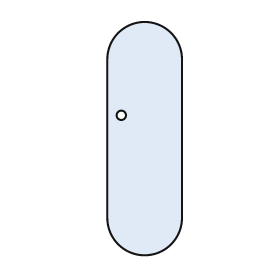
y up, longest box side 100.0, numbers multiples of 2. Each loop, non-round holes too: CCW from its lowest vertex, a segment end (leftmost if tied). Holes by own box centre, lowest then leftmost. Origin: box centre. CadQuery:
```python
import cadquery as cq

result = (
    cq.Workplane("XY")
    .moveTo(-16.0, -34.0)
    .threePointArc((0.0, -50.0), (16.0, -34.0))
    .lineTo(16.0, 34.0)
    .threePointArc((0.0, 50.0), (-16.0, 34.0))
    .close()
    .moveTo(-10.0, 10.0)
    .circle(2.0)
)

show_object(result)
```